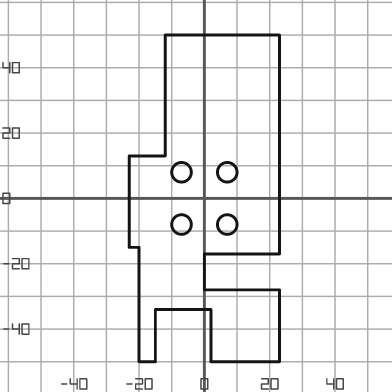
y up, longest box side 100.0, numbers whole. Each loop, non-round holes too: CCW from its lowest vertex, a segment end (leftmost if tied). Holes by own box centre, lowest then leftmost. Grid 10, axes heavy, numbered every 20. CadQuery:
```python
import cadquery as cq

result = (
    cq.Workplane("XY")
    .moveTo(-20.0, -50.0)
    .lineTo(-15.0, -50.0)
    .lineTo(-15.0, -34.0)
    .lineTo(2.0, -34.0)
    .lineTo(2.0, -50.0)
    .lineTo(23.0, -50.0)
    .lineTo(23.0, -28.0)
    .lineTo(0.0, -28.0)
    .lineTo(0.0, -17.0)
    .lineTo(23.0, -17.0)
    .lineTo(23.0, 50.0)
    .lineTo(-12.0, 50.0)
    .lineTo(-12.0, 13.0)
    .lineTo(-23.0, 13.0)
    .lineTo(-23.0, -15.0)
    .lineTo(-20.0, -15.0)
    .close()
    .moveTo(-7.0, -8.0)
    .circle(3.0)
    .moveTo(7.0, -8.0)
    .circle(3.0)
    .moveTo(-7.0, 8.0)
    .circle(3.0)
    .moveTo(7.0, 8.0)
    .circle(3.0)
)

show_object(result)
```